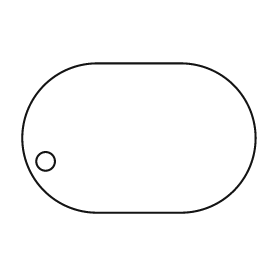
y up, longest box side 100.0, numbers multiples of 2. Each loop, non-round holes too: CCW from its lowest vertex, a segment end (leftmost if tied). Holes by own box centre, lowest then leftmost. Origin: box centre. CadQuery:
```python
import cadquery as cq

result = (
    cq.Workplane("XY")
    .moveTo(-18.0, -32.0)
    .lineTo(18.0, -32.0)
    .threePointArc((50.0, 0.0), (18.0, 32.0))
    .lineTo(-18.0, 32.0)
    .threePointArc((-50.0, 0.0), (-18.0, -32.0))
    .close()
    .moveTo(-40.0, -10.0)
    .circle(4.0)
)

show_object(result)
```